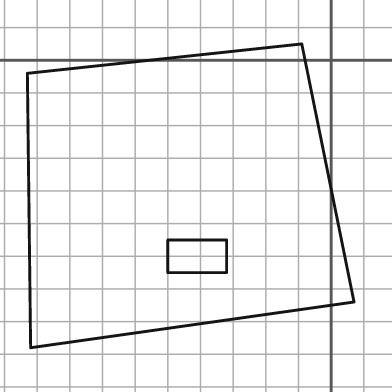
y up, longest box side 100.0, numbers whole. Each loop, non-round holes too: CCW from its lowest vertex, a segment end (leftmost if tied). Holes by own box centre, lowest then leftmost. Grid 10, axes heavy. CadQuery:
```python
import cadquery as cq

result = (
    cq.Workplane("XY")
    .moveTo(-92.0, -88.0)
    .lineTo(7.0, -74.0)
    .lineTo(-9.0, 5.0)
    .lineTo(-93.0, -4.0)
    .close()
    .moveTo(-50.0, -65.0)
    .lineTo(-32.0, -65.0)
    .lineTo(-32.0, -55.0)
    .lineTo(-50.0, -55.0)
    .close()
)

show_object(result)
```